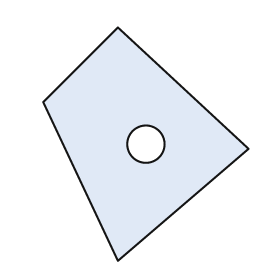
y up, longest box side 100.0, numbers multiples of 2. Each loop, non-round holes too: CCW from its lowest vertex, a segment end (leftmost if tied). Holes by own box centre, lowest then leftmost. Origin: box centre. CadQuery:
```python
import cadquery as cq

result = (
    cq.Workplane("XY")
    .moveTo(-12.0, -50.0)
    .lineTo(44.0, -2.0)
    .lineTo(-12.0, 50.0)
    .lineTo(-44.0, 18.0)
    .close()
    .moveTo(0.0, 0.0)
    .circle(8.0)
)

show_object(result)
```